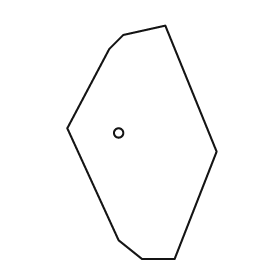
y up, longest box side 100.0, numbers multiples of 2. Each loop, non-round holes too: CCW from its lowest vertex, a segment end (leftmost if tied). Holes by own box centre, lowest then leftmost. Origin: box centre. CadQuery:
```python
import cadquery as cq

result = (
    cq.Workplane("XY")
    .moveTo(0.0, -50.0)
    .lineTo(14.0, -50.0)
    .lineTo(32.0, -4.0)
    .lineTo(10.0, 50.0)
    .lineTo(-8.0, 46.0)
    .lineTo(-14.0, 40.0)
    .lineTo(-32.0, 6.0)
    .lineTo(-10.0, -42.0)
    .close()
    .moveTo(-10.0, 4.0)
    .circle(2.0)
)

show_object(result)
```